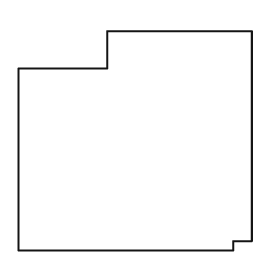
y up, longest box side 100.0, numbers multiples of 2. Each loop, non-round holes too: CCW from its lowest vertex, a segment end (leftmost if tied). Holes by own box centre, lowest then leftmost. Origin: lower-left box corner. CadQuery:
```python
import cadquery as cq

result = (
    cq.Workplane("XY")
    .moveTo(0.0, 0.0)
    .lineTo(92.0, 0.0)
    .lineTo(92.0, 4.0)
    .lineTo(100.0, 4.0)
    .lineTo(100.0, 94.0)
    .lineTo(38.0, 94.0)
    .lineTo(38.0, 78.0)
    .lineTo(0.0, 78.0)
    .close()
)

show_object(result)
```